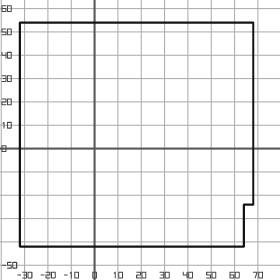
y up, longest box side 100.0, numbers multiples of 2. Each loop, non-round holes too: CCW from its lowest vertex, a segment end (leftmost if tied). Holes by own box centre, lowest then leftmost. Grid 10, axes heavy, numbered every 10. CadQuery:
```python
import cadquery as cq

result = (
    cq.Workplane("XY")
    .moveTo(-32.0, -42.0)
    .lineTo(64.0, -42.0)
    .lineTo(64.0, -24.0)
    .lineTo(68.0, -24.0)
    .lineTo(68.0, 54.0)
    .lineTo(-32.0, 54.0)
    .close()
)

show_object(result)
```